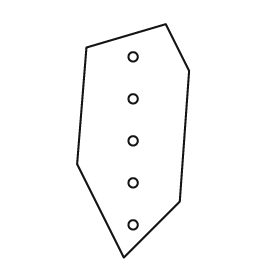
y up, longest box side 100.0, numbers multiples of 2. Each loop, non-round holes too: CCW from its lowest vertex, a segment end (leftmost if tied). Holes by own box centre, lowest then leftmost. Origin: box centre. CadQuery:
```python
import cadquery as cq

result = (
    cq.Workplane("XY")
    .moveTo(-4.0, -50.0)
    .lineTo(20.0, -26.0)
    .lineTo(24.0, 30.0)
    .lineTo(14.0, 50.0)
    .lineTo(-20.0, 40.0)
    .lineTo(-24.0, -10.0)
    .close()
    .moveTo(0.0, -36.0)
    .circle(2.0)
    .moveTo(0.0, -18.0)
    .circle(2.0)
    .moveTo(0.0, 0.0)
    .circle(2.0)
    .moveTo(0.0, 18.0)
    .circle(2.0)
    .moveTo(0.0, 36.0)
    .circle(2.0)
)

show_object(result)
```